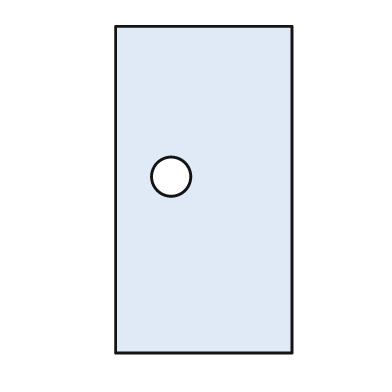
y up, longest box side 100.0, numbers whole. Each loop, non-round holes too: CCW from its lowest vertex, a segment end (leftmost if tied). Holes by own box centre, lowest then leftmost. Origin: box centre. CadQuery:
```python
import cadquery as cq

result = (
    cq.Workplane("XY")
    .moveTo(-27.0, -50.0)
    .lineTo(27.0, -50.0)
    .lineTo(27.0, 50.0)
    .lineTo(-27.0, 50.0)
    .close()
    .moveTo(-10.0, 4.0)
    .circle(6.0)
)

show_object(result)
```